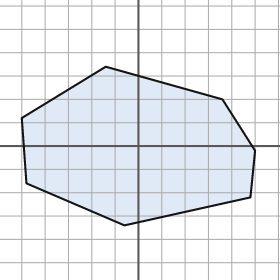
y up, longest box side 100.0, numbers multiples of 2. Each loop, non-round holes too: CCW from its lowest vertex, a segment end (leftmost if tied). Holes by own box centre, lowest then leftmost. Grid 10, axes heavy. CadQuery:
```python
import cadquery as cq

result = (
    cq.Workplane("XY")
    .moveTo(-6.0, -34.0)
    .lineTo(48.0, -22.0)
    .lineTo(50.0, -2.0)
    .lineTo(36.0, 20.0)
    .lineTo(-14.0, 34.0)
    .lineTo(-50.0, 12.0)
    .lineTo(-48.0, -16.0)
    .close()
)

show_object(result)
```